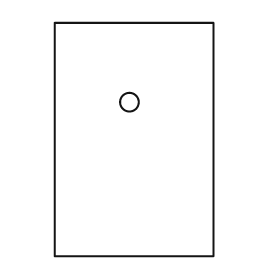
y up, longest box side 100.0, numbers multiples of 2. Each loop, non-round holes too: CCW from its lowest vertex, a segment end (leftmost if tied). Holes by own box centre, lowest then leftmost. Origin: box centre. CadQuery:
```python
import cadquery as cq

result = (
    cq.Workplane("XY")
    .moveTo(-34.0, -50.0)
    .lineTo(34.0, -50.0)
    .lineTo(34.0, 50.0)
    .lineTo(-34.0, 50.0)
    .close()
    .moveTo(-2.0, 16.0)
    .circle(4.0)
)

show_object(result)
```